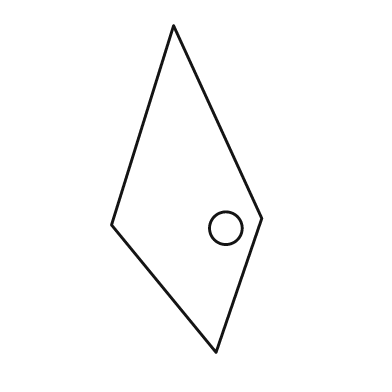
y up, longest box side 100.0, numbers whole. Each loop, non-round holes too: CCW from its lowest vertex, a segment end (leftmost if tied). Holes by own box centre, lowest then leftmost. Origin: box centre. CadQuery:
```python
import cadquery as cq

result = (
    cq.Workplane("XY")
    .moveTo(9.0, -50.0)
    .lineTo(23.0, -9.0)
    .lineTo(-4.0, 50.0)
    .lineTo(-23.0, -11.0)
    .close()
    .moveTo(12.0, -12.0)
    .circle(5.0)
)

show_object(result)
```